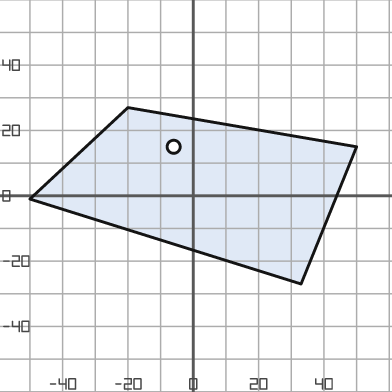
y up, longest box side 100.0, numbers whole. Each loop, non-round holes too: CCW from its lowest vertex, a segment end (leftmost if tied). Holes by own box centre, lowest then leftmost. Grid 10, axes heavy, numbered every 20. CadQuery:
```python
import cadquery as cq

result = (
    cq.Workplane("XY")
    .moveTo(33.0, -27.0)
    .lineTo(50.0, 15.0)
    .lineTo(-20.0, 27.0)
    .lineTo(-50.0, -1.0)
    .close()
    .moveTo(-6.0, 15.0)
    .circle(2.0)
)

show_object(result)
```